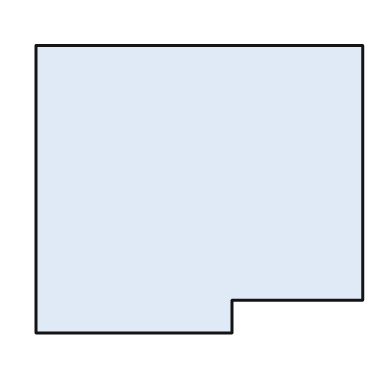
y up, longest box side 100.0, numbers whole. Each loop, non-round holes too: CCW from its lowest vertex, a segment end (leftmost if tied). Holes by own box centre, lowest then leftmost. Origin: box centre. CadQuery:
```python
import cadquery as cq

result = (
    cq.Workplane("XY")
    .moveTo(-50.0, -44.0)
    .lineTo(10.0, -44.0)
    .lineTo(10.0, -34.0)
    .lineTo(50.0, -34.0)
    .lineTo(50.0, 44.0)
    .lineTo(-50.0, 44.0)
    .close()
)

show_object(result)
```